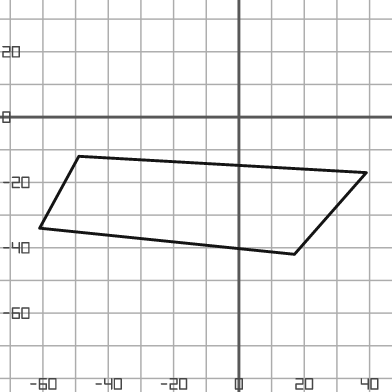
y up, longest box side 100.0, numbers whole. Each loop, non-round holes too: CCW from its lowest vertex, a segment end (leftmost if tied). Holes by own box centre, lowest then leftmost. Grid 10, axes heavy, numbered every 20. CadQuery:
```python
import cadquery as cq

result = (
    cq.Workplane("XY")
    .moveTo(17.0, -42.0)
    .lineTo(39.0, -17.0)
    .lineTo(-49.0, -12.0)
    .lineTo(-61.0, -34.0)
    .close()
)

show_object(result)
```